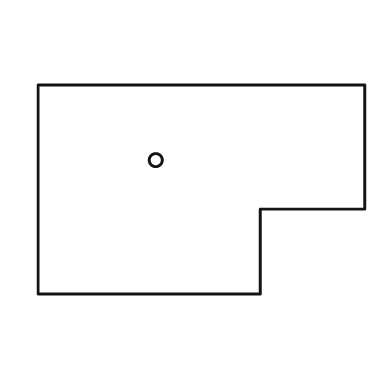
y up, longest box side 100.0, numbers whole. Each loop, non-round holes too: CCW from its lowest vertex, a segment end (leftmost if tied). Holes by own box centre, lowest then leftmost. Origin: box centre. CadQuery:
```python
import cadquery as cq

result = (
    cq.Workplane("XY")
    .moveTo(-50.0, -32.0)
    .lineTo(18.0, -32.0)
    .lineTo(18.0, -6.0)
    .lineTo(50.0, -6.0)
    .lineTo(50.0, 32.0)
    .lineTo(-50.0, 32.0)
    .close()
    .moveTo(-14.0, 9.0)
    .circle(2.0)
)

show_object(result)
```